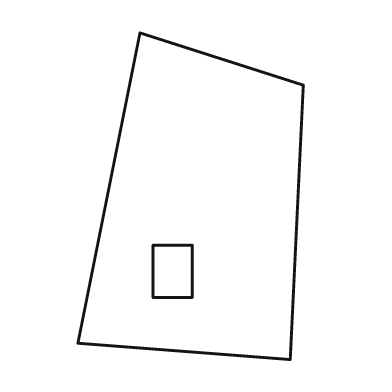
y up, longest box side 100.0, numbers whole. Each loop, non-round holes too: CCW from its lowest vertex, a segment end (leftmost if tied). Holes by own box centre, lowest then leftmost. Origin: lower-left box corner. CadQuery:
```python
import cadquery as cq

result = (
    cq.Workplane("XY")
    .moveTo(65.0, 0.0)
    .lineTo(69.0, 84.0)
    .lineTo(19.0, 100.0)
    .lineTo(0.0, 5.0)
    .close()
    .moveTo(23.0, 19.0)
    .lineTo(35.0, 19.0)
    .lineTo(35.0, 35.0)
    .lineTo(23.0, 35.0)
    .close()
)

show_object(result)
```